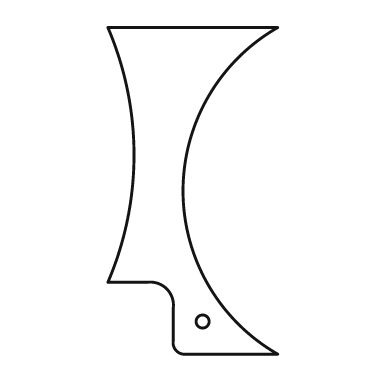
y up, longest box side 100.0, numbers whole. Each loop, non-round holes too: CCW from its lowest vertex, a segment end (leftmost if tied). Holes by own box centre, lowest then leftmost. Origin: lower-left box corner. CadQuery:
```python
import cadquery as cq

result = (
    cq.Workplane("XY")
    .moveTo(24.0, 0.0)
    .lineTo(52.0, 0.0)
    .threePointArc((23.0, 50.0), (52.0, 100.0))
    .lineTo(0.0, 100.0)
    .threePointArc((8.0, 61.0), (0.0, 22.0))
    .lineTo(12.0, 22.0)
    .threePointArc((18.0, 20.0), (20.0, 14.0))
    .lineTo(20.0, 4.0)
    .threePointArc((21.0, 1.0), (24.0, 0.0))
    .close()
    .moveTo(29.0, 10.0)
    .circle(2.0)
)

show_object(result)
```